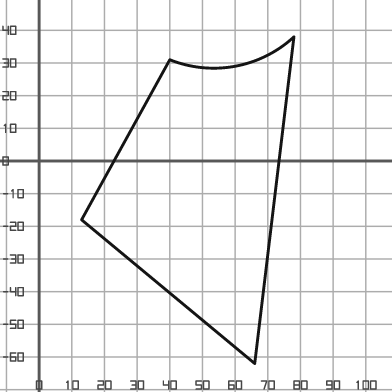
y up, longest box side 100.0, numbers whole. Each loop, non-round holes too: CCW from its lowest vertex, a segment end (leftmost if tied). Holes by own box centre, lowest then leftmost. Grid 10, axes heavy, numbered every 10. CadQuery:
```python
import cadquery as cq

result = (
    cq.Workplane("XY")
    .moveTo(66.0, -62.0)
    .lineTo(78.0, 38.0)
    .threePointArc((60.0, 29.0), (40.0, 31.0))
    .lineTo(13.0, -18.0)
    .close()
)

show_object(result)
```